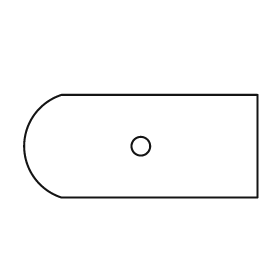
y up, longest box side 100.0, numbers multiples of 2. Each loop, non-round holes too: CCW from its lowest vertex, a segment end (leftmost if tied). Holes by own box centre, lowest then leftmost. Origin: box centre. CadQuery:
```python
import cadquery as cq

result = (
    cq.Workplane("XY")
    .moveTo(-34.0, -22.0)
    .lineTo(50.0, -22.0)
    .lineTo(50.0, 22.0)
    .lineTo(-34.0, 22.0)
    .threePointArc((-50.0, 0.0), (-34.0, -22.0))
    .close()
    .moveTo(0.0, 0.0)
    .circle(4.0)
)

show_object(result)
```